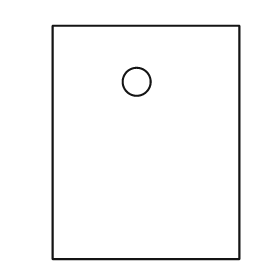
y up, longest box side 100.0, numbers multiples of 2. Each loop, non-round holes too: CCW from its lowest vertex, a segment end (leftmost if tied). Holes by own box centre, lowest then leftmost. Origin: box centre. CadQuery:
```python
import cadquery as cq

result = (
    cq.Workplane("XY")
    .moveTo(-40.0, -50.0)
    .lineTo(40.0, -50.0)
    .lineTo(40.0, 50.0)
    .lineTo(-40.0, 50.0)
    .close()
    .moveTo(-4.0, 26.0)
    .circle(6.0)
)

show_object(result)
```